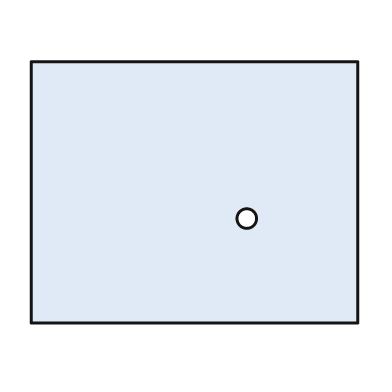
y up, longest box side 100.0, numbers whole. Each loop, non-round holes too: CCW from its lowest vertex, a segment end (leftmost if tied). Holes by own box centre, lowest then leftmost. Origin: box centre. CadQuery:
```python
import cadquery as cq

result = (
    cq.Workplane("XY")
    .moveTo(-50.0, -40.0)
    .lineTo(50.0, -40.0)
    .lineTo(50.0, 40.0)
    .lineTo(-50.0, 40.0)
    .close()
    .moveTo(16.0, -8.0)
    .circle(3.0)
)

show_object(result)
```